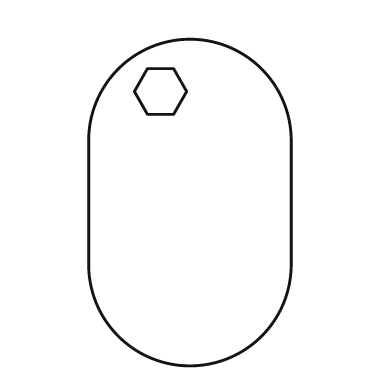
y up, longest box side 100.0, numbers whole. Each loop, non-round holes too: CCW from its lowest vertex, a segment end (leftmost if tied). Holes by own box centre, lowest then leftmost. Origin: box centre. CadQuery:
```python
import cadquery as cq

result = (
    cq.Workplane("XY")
    .moveTo(-31.0, -19.0)
    .threePointArc((0.0, -50.0), (31.0, -19.0))
    .lineTo(31.0, 19.0)
    .threePointArc((0.0, 50.0), (-31.0, 19.0))
    .close()
    .moveTo(-13.0, 27.0)
    .lineTo(-5.0, 27.0)
    .lineTo(-1.0, 34.0)
    .lineTo(-5.0, 41.0)
    .lineTo(-13.0, 41.0)
    .lineTo(-17.0, 34.0)
    .close()
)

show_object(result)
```